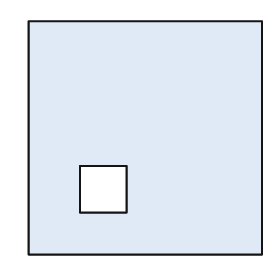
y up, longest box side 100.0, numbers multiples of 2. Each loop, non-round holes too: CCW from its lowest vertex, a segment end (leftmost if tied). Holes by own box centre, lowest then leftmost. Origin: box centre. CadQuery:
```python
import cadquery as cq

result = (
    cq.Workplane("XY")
    .moveTo(-50.0, -50.0)
    .lineTo(50.0, -50.0)
    .lineTo(50.0, 50.0)
    .lineTo(-50.0, 50.0)
    .close()
    .moveTo(-28.0, -32.0)
    .lineTo(-8.0, -32.0)
    .lineTo(-8.0, -12.0)
    .lineTo(-28.0, -12.0)
    .close()
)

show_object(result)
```